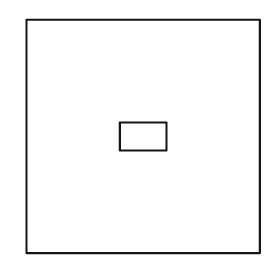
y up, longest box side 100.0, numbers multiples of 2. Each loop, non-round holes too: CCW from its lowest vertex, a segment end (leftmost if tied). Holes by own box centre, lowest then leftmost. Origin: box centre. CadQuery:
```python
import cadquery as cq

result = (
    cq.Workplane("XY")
    .moveTo(-50.0, -50.0)
    .lineTo(50.0, -50.0)
    .lineTo(50.0, 50.0)
    .lineTo(-50.0, 50.0)
    .close()
    .moveTo(-10.0, -6.0)
    .lineTo(10.0, -6.0)
    .lineTo(10.0, 6.0)
    .lineTo(-10.0, 6.0)
    .close()
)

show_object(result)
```